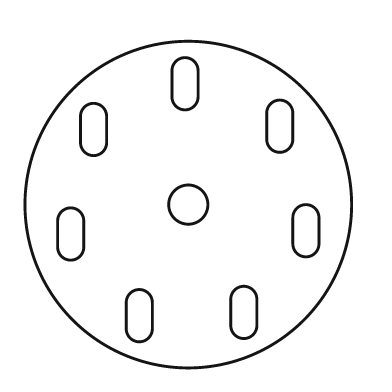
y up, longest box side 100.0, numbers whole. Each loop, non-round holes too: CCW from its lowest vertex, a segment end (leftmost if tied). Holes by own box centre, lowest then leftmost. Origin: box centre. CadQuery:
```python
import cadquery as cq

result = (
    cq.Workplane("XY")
    .moveTo(0.0, 0.0)
    .circle(50.0)
    .moveTo(-19.0, -38.0)
    .threePointArc((-15.0, -42.0), (-11.0, -38.0))
    .lineTo(-11.0, -30.0)
    .threePointArc((-15.0, -26.0), (-19.0, -30.0))
    .close()
    .moveTo(13.0, -37.0)
    .threePointArc((17.0, -41.0), (21.0, -37.0))
    .lineTo(21.0, -29.0)
    .threePointArc((17.0, -25.0), (13.0, -29.0))
    .close()
    .moveTo(-40.0, -13.0)
    .threePointArc((-36.0, -17.0), (-32.0, -13.0))
    .lineTo(-32.0, -5.0)
    .threePointArc((-36.0, -1.0), (-40.0, -5.0))
    .close()
    .moveTo(32.0, -12.0)
    .threePointArc((36.0, -16.0), (40.0, -12.0))
    .lineTo(40.0, -4.0)
    .threePointArc((36.0, 0.0), (32.0, -4.0))
    .close()
    .moveTo(0.0, 0.0)
    .circle(6.0)
    .moveTo(-33.0, 19.0)
    .threePointArc((-29.0, 15.0), (-25.0, 19.0))
    .lineTo(-25.0, 27.0)
    .threePointArc((-29.0, 31.0), (-33.0, 27.0))
    .close()
    .moveTo(24.0, 20.0)
    .threePointArc((28.0, 16.0), (32.0, 20.0))
    .lineTo(32.0, 28.0)
    .threePointArc((28.0, 32.0), (24.0, 28.0))
    .close()
    .moveTo(-5.0, 33.0)
    .threePointArc((-1.0, 29.0), (3.0, 33.0))
    .lineTo(3.0, 41.0)
    .threePointArc((-1.0, 45.0), (-5.0, 41.0))
    .close()
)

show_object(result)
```